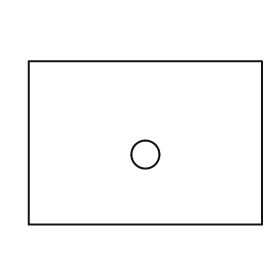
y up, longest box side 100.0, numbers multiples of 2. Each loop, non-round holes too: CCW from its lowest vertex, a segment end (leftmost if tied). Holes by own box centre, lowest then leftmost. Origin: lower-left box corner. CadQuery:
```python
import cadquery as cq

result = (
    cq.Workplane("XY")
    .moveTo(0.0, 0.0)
    .lineTo(100.0, 0.0)
    .lineTo(100.0, 70.0)
    .lineTo(0.0, 70.0)
    .close()
    .moveTo(50.0, 30.0)
    .circle(6.0)
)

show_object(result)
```